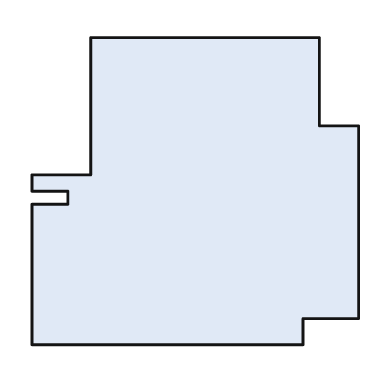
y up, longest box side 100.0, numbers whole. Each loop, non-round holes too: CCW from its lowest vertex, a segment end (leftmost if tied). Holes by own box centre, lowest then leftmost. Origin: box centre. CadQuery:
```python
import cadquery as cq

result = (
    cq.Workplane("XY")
    .moveTo(-50.0, -47.0)
    .lineTo(33.0, -47.0)
    .lineTo(33.0, -39.0)
    .lineTo(50.0, -39.0)
    .lineTo(50.0, 20.0)
    .lineTo(38.0, 20.0)
    .lineTo(38.0, 47.0)
    .lineTo(-32.0, 47.0)
    .lineTo(-32.0, 5.0)
    .lineTo(-50.0, 5.0)
    .lineTo(-50.0, 0.0)
    .lineTo(-39.0, 0.0)
    .lineTo(-39.0, -4.0)
    .lineTo(-50.0, -4.0)
    .close()
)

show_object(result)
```